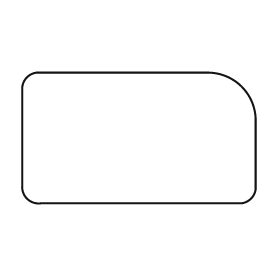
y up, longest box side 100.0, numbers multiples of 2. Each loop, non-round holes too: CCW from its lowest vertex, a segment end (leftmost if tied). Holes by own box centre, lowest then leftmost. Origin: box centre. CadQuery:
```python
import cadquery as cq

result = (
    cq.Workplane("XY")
    .moveTo(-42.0, -28.0)
    .lineTo(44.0, -28.0)
    .threePointArc((48.0, -26.0), (50.0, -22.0))
    .lineTo(50.0, 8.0)
    .threePointArc((44.0, 22.0), (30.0, 28.0))
    .lineTo(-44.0, 28.0)
    .threePointArc((-48.0, 26.0), (-50.0, 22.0))
    .lineTo(-50.0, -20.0)
    .threePointArc((-48.0, -26.0), (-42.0, -28.0))
    .close()
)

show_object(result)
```